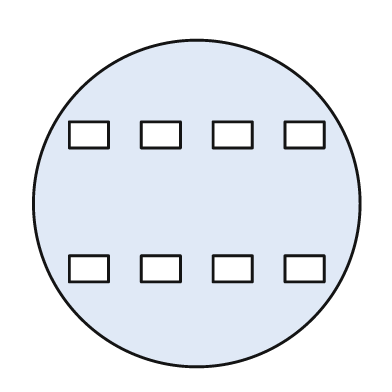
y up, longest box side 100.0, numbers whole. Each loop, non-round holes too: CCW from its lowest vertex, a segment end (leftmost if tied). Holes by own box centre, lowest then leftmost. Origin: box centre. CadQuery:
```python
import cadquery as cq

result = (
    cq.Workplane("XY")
    .moveTo(0.0, 0.0)
    .circle(50.0)
    .moveTo(-39.0, -24.0)
    .lineTo(-27.0, -24.0)
    .lineTo(-27.0, -16.0)
    .lineTo(-39.0, -16.0)
    .close()
    .moveTo(-17.0, -24.0)
    .lineTo(-5.0, -24.0)
    .lineTo(-5.0, -16.0)
    .lineTo(-17.0, -16.0)
    .close()
    .moveTo(5.0, -24.0)
    .lineTo(17.0, -24.0)
    .lineTo(17.0, -16.0)
    .lineTo(5.0, -16.0)
    .close()
    .moveTo(27.0, -24.0)
    .lineTo(39.0, -24.0)
    .lineTo(39.0, -16.0)
    .lineTo(27.0, -16.0)
    .close()
    .moveTo(-39.0, 17.0)
    .lineTo(-27.0, 17.0)
    .lineTo(-27.0, 25.0)
    .lineTo(-39.0, 25.0)
    .close()
    .moveTo(-17.0, 17.0)
    .lineTo(-5.0, 17.0)
    .lineTo(-5.0, 25.0)
    .lineTo(-17.0, 25.0)
    .close()
    .moveTo(5.0, 17.0)
    .lineTo(17.0, 17.0)
    .lineTo(17.0, 25.0)
    .lineTo(5.0, 25.0)
    .close()
    .moveTo(27.0, 17.0)
    .lineTo(39.0, 17.0)
    .lineTo(39.0, 25.0)
    .lineTo(27.0, 25.0)
    .close()
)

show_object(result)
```